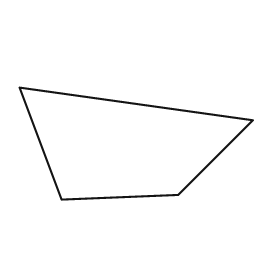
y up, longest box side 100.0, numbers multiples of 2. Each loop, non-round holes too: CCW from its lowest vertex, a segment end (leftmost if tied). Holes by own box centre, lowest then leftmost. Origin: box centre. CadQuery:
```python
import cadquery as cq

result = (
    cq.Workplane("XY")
    .moveTo(-32.0, -24.0)
    .lineTo(18.0, -22.0)
    .lineTo(50.0, 10.0)
    .lineTo(-50.0, 24.0)
    .close()
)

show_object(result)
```